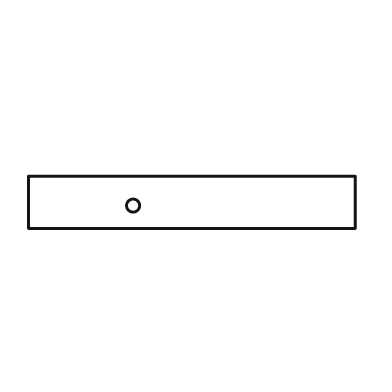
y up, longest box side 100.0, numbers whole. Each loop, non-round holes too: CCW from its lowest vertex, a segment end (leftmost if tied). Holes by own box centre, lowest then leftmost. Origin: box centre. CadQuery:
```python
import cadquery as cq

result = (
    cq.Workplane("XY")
    .moveTo(-50.0, -8.0)
    .lineTo(50.0, -8.0)
    .lineTo(50.0, 8.0)
    .lineTo(-50.0, 8.0)
    .close()
    .moveTo(-18.0, -1.0)
    .circle(2.0)
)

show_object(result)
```